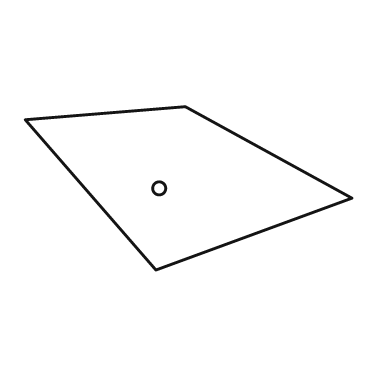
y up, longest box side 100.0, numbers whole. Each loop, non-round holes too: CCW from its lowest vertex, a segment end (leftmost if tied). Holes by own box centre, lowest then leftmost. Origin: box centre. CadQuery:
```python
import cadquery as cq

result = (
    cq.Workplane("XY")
    .moveTo(-10.0, -25.0)
    .lineTo(50.0, -3.0)
    .lineTo(-1.0, 25.0)
    .lineTo(-50.0, 21.0)
    .close()
    .moveTo(-9.0, 0.0)
    .circle(2.0)
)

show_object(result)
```